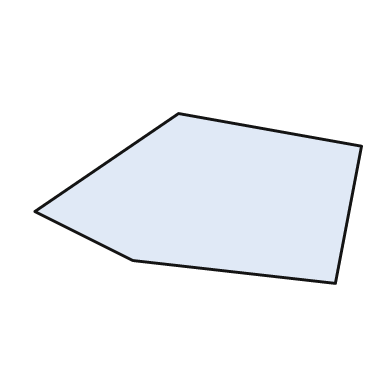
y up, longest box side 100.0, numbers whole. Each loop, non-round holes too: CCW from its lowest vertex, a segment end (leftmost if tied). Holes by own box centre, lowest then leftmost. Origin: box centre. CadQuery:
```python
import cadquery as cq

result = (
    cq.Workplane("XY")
    .moveTo(42.0, -26.0)
    .lineTo(50.0, 16.0)
    .lineTo(-6.0, 26.0)
    .lineTo(-50.0, -4.0)
    .lineTo(-20.0, -19.0)
    .close()
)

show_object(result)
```